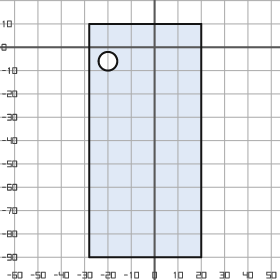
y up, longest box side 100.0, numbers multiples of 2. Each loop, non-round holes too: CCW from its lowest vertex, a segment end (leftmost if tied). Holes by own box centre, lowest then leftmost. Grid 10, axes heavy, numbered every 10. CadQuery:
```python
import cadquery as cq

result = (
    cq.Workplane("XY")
    .moveTo(-28.0, -90.0)
    .lineTo(20.0, -90.0)
    .lineTo(20.0, 10.0)
    .lineTo(-28.0, 10.0)
    .close()
    .moveTo(-20.0, -6.0)
    .circle(4.0)
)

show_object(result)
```